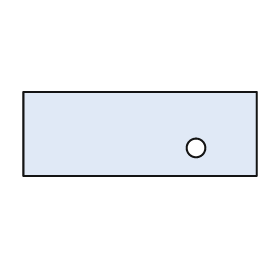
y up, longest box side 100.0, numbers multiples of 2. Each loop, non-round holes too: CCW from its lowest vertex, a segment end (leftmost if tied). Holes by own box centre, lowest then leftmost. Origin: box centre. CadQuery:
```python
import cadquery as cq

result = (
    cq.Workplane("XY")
    .moveTo(-50.0, -18.0)
    .lineTo(50.0, -18.0)
    .lineTo(50.0, 18.0)
    .lineTo(-50.0, 18.0)
    .close()
    .moveTo(24.0, -6.0)
    .circle(4.0)
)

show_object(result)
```